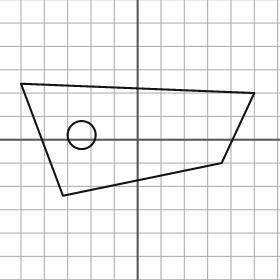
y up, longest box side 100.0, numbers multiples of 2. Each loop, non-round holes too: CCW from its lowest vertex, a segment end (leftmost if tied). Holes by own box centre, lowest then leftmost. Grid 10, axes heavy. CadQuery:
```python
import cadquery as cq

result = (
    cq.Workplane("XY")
    .moveTo(-32.0, -24.0)
    .lineTo(36.0, -10.0)
    .lineTo(50.0, 20.0)
    .lineTo(-50.0, 24.0)
    .close()
    .moveTo(-24.0, 2.0)
    .circle(6.0)
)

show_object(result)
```